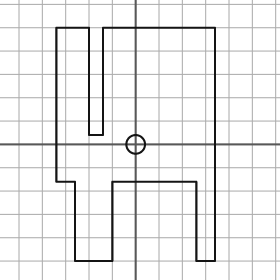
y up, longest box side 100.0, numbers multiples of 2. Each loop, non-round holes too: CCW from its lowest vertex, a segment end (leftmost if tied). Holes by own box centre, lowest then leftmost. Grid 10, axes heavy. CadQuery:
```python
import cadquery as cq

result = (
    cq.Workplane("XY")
    .moveTo(-26.0, -50.0)
    .lineTo(-10.0, -50.0)
    .lineTo(-10.0, -16.0)
    .lineTo(26.0, -16.0)
    .lineTo(26.0, -50.0)
    .lineTo(34.0, -50.0)
    .lineTo(34.0, 50.0)
    .lineTo(-14.0, 50.0)
    .lineTo(-14.0, 4.0)
    .lineTo(-20.0, 4.0)
    .lineTo(-20.0, 50.0)
    .lineTo(-34.0, 50.0)
    .lineTo(-34.0, -16.0)
    .lineTo(-26.0, -16.0)
    .close()
    .moveTo(0.0, 0.0)
    .circle(4.0)
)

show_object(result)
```